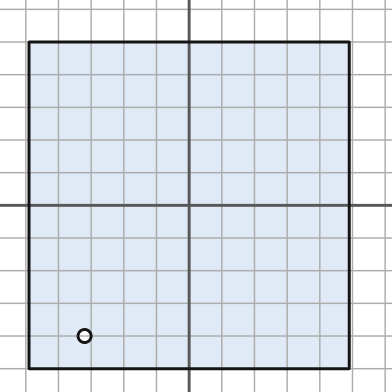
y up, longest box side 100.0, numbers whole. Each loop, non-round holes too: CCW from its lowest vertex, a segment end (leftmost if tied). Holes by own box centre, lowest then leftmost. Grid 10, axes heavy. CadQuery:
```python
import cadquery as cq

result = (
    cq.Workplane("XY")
    .moveTo(-49.0, -50.0)
    .lineTo(49.0, -50.0)
    .lineTo(49.0, 50.0)
    .lineTo(-49.0, 50.0)
    .close()
    .moveTo(-32.0, -40.0)
    .circle(2.0)
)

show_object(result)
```